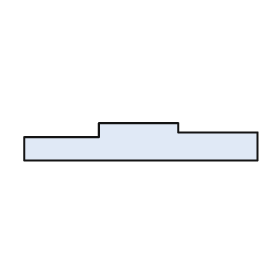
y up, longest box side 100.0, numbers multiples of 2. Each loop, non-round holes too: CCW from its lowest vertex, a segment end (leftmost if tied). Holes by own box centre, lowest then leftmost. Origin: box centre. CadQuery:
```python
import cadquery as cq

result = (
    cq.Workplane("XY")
    .moveTo(-50.0, -8.0)
    .lineTo(50.0, -8.0)
    .lineTo(50.0, 4.0)
    .lineTo(16.0, 4.0)
    .lineTo(16.0, 8.0)
    .lineTo(-18.0, 8.0)
    .lineTo(-18.0, 2.0)
    .lineTo(-50.0, 2.0)
    .close()
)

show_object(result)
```